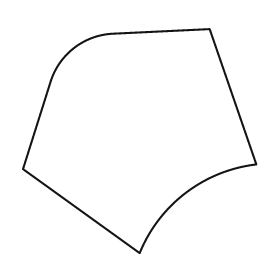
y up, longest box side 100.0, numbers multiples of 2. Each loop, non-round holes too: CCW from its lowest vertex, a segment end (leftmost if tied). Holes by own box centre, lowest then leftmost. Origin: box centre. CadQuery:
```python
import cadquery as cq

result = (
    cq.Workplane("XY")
    .moveTo(0.0, -48.0)
    .threePointArc((20.0, -22.0), (50.0, -10.0))
    .lineTo(30.0, 48.0)
    .lineTo(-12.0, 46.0)
    .threePointArc((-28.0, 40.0), (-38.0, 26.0))
    .lineTo(-50.0, -12.0)
    .close()
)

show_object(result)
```